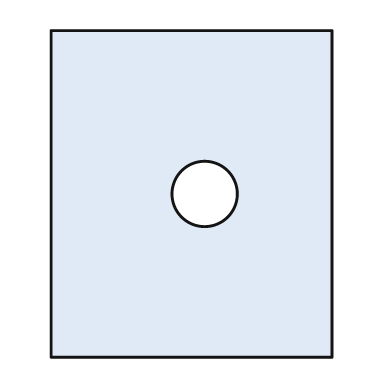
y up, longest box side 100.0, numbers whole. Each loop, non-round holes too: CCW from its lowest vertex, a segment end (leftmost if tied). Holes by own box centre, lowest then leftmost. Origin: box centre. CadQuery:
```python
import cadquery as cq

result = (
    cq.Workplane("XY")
    .moveTo(-43.0, -50.0)
    .lineTo(43.0, -50.0)
    .lineTo(43.0, 50.0)
    .lineTo(-43.0, 50.0)
    .close()
    .moveTo(4.0, 0.0)
    .circle(10.0)
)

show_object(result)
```